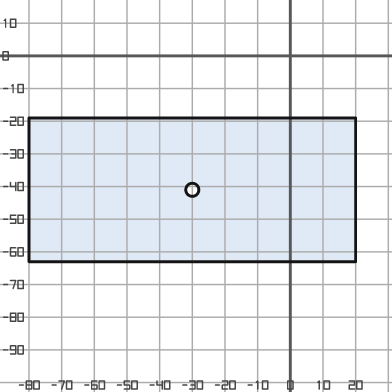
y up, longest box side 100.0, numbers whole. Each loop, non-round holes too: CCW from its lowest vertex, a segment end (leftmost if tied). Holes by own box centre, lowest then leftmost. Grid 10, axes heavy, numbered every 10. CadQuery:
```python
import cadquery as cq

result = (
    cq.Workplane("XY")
    .moveTo(-80.0, -63.0)
    .lineTo(20.0, -63.0)
    .lineTo(20.0, -19.0)
    .lineTo(-80.0, -19.0)
    .close()
    .moveTo(-30.0, -41.0)
    .circle(2.0)
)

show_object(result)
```